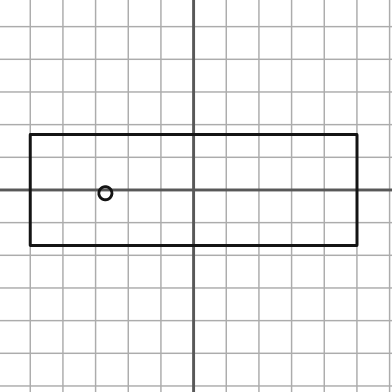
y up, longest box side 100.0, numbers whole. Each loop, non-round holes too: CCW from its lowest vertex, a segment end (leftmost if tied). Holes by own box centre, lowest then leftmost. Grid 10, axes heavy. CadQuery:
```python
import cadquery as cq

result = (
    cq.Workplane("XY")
    .moveTo(-50.0, -17.0)
    .lineTo(50.0, -17.0)
    .lineTo(50.0, 17.0)
    .lineTo(-50.0, 17.0)
    .close()
    .moveTo(-27.0, -1.0)
    .circle(2.0)
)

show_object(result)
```